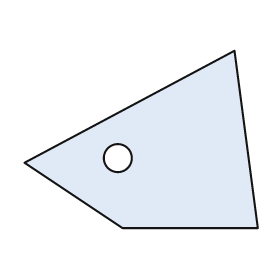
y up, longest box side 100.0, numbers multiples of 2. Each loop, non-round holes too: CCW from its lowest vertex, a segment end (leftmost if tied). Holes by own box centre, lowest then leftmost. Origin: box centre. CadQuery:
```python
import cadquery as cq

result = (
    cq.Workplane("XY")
    .moveTo(-8.0, -38.0)
    .lineTo(50.0, -38.0)
    .lineTo(40.0, 38.0)
    .lineTo(-50.0, -10.0)
    .close()
    .moveTo(-10.0, -8.0)
    .circle(6.0)
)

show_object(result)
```